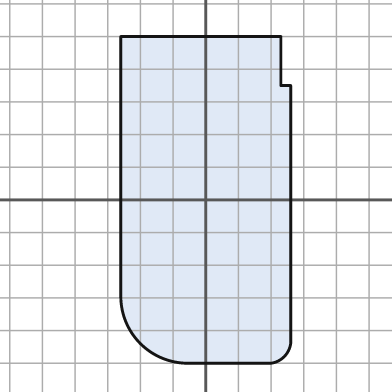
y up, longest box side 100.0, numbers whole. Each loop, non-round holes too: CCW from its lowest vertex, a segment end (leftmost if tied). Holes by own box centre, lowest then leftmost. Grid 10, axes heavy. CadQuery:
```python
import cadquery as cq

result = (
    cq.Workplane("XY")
    .moveTo(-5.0, -50.0)
    .lineTo(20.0, -50.0)
    .threePointArc((24.0, -48.0), (26.0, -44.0))
    .lineTo(26.0, 35.0)
    .lineTo(23.0, 35.0)
    .lineTo(23.0, 50.0)
    .lineTo(-26.0, 50.0)
    .lineTo(-26.0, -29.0)
    .threePointArc((-20.0, -44.0), (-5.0, -50.0))
    .close()
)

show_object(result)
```